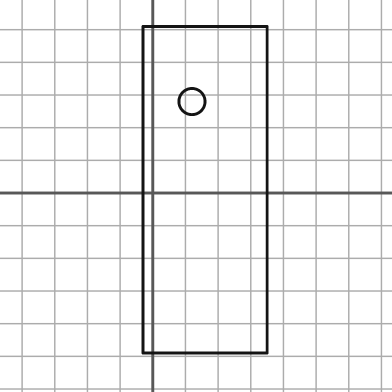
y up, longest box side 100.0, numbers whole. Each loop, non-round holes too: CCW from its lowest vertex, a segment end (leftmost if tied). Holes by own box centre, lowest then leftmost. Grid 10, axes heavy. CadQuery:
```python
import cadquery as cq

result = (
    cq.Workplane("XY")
    .moveTo(-3.0, -49.0)
    .lineTo(35.0, -49.0)
    .lineTo(35.0, 51.0)
    .lineTo(-3.0, 51.0)
    .close()
    .moveTo(12.0, 28.0)
    .circle(4.0)
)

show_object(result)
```